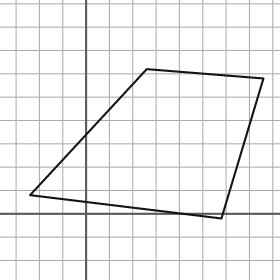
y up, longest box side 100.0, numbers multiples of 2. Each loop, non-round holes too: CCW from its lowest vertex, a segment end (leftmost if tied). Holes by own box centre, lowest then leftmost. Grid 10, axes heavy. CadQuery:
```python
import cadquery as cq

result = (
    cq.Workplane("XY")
    .moveTo(58.0, -2.0)
    .lineTo(76.0, 58.0)
    .lineTo(26.0, 62.0)
    .lineTo(-24.0, 8.0)
    .close()
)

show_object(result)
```